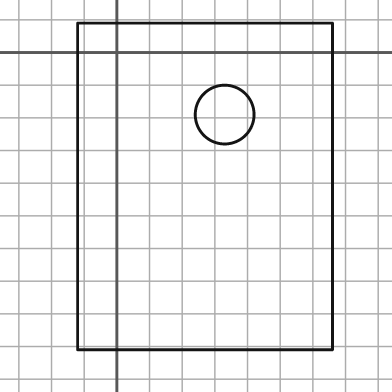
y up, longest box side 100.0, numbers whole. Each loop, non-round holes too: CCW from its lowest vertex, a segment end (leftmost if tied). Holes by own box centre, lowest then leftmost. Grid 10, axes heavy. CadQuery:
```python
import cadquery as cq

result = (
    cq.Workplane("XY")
    .moveTo(-12.0, -91.0)
    .lineTo(66.0, -91.0)
    .lineTo(66.0, 9.0)
    .lineTo(-12.0, 9.0)
    .close()
    .moveTo(33.0, -19.0)
    .circle(9.0)
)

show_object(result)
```